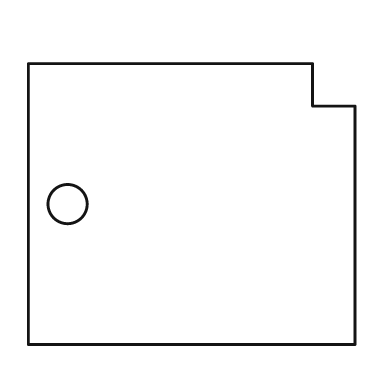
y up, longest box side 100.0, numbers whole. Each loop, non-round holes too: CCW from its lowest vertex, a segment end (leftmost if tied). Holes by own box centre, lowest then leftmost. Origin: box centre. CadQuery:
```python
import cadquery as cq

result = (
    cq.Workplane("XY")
    .moveTo(-50.0, -43.0)
    .lineTo(50.0, -43.0)
    .lineTo(50.0, 30.0)
    .lineTo(37.0, 30.0)
    .lineTo(37.0, 43.0)
    .lineTo(-50.0, 43.0)
    .close()
    .moveTo(-38.0, 0.0)
    .circle(6.0)
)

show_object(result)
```